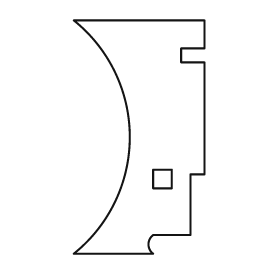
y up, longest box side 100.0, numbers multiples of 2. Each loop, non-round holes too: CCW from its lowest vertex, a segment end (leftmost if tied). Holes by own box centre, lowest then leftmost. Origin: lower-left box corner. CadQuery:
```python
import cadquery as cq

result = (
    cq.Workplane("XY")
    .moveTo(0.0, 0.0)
    .lineTo(34.0, 0.0)
    .threePointArc((32.0, 4.0), (34.0, 8.0))
    .lineTo(50.0, 8.0)
    .lineTo(50.0, 34.0)
    .lineTo(56.0, 34.0)
    .lineTo(56.0, 82.0)
    .lineTo(46.0, 82.0)
    .lineTo(46.0, 88.0)
    .lineTo(56.0, 88.0)
    .lineTo(56.0, 100.0)
    .lineTo(0.0, 100.0)
    .threePointArc((24.0, 50.0), (0.0, 0.0))
    .close()
    .moveTo(34.0, 28.0)
    .lineTo(42.0, 28.0)
    .lineTo(42.0, 36.0)
    .lineTo(34.0, 36.0)
    .close()
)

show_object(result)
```